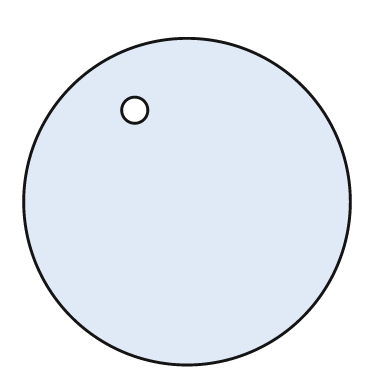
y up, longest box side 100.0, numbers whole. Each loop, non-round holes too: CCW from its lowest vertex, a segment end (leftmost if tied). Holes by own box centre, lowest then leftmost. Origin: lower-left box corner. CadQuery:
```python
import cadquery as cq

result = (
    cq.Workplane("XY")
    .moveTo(50.0, 50.0)
    .circle(50.0)
    .moveTo(34.0, 78.0)
    .circle(4.0)
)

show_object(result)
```